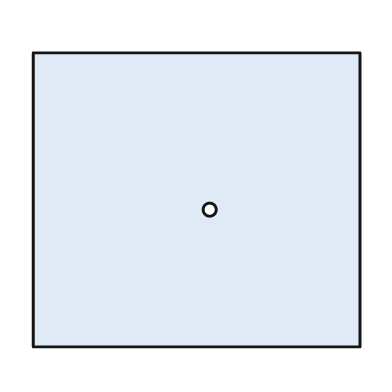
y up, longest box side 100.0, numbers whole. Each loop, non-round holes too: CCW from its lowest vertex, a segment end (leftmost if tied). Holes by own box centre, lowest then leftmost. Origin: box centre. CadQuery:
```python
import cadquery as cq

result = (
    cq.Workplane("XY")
    .moveTo(-50.0, -45.0)
    .lineTo(50.0, -45.0)
    .lineTo(50.0, 45.0)
    .lineTo(-50.0, 45.0)
    .close()
    .moveTo(4.0, -3.0)
    .circle(2.0)
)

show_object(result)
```